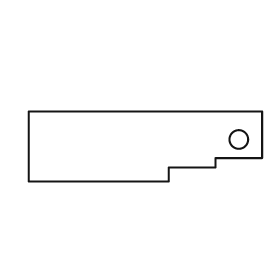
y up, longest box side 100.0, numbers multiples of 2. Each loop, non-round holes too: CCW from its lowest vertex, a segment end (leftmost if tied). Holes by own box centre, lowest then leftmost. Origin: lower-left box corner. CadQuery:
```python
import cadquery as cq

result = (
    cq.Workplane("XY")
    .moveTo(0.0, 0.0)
    .lineTo(60.0, 0.0)
    .lineTo(60.0, 6.0)
    .lineTo(80.0, 6.0)
    .lineTo(80.0, 10.0)
    .lineTo(100.0, 10.0)
    .lineTo(100.0, 30.0)
    .lineTo(0.0, 30.0)
    .close()
    .moveTo(90.0, 18.0)
    .circle(4.0)
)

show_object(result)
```